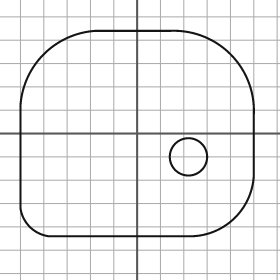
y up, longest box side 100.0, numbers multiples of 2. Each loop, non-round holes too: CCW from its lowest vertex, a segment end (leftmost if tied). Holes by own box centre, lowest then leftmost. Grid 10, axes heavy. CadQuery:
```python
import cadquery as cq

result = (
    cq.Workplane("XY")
    .moveTo(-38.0, -44.0)
    .lineTo(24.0, -44.0)
    .threePointArc((42.0, -36.0), (50.0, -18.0))
    .lineTo(50.0, 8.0)
    .threePointArc((40.0, 34.0), (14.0, 44.0))
    .lineTo(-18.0, 44.0)
    .threePointArc((-40.0, 34.0), (-50.0, 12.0))
    .lineTo(-50.0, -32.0)
    .threePointArc((-46.0, -40.0), (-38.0, -44.0))
    .close()
    .moveTo(22.0, -10.0)
    .circle(8.0)
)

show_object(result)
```